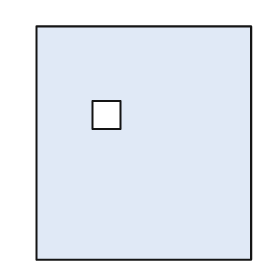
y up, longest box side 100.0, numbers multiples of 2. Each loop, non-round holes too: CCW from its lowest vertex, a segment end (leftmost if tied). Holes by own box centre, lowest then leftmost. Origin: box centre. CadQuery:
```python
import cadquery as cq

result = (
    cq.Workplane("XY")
    .moveTo(-46.0, -50.0)
    .lineTo(46.0, -50.0)
    .lineTo(46.0, 50.0)
    .lineTo(-46.0, 50.0)
    .close()
    .moveTo(-22.0, 6.0)
    .lineTo(-10.0, 6.0)
    .lineTo(-10.0, 18.0)
    .lineTo(-22.0, 18.0)
    .close()
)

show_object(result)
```